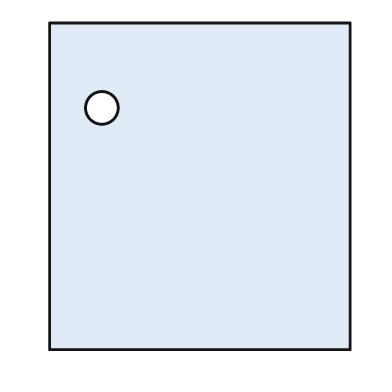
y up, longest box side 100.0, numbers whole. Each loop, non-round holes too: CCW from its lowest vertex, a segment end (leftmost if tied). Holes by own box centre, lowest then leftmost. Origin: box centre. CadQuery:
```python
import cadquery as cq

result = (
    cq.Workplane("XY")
    .moveTo(-46.0, -50.0)
    .lineTo(46.0, -50.0)
    .lineTo(46.0, 50.0)
    .lineTo(-46.0, 50.0)
    .close()
    .moveTo(-30.0, 24.0)
    .circle(5.0)
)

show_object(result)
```